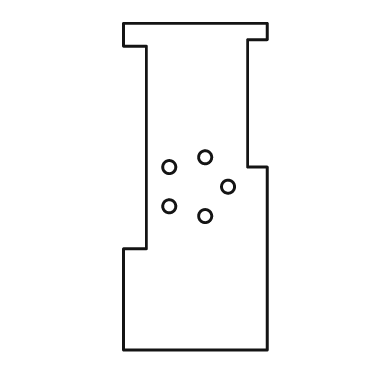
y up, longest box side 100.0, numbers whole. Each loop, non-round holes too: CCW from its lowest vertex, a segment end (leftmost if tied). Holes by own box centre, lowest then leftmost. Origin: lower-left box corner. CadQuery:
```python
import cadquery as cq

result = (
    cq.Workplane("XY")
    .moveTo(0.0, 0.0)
    .lineTo(44.0, 0.0)
    .lineTo(44.0, 56.0)
    .lineTo(38.0, 56.0)
    .lineTo(38.0, 95.0)
    .lineTo(44.0, 95.0)
    .lineTo(44.0, 100.0)
    .lineTo(0.0, 100.0)
    .lineTo(0.0, 93.0)
    .lineTo(7.0, 93.0)
    .lineTo(7.0, 31.0)
    .lineTo(0.0, 31.0)
    .close()
    .moveTo(25.0, 41.0)
    .circle(2.0)
    .moveTo(14.0, 44.0)
    .circle(2.0)
    .moveTo(32.0, 50.0)
    .circle(2.0)
    .moveTo(14.0, 56.0)
    .circle(2.0)
    .moveTo(25.0, 59.0)
    .circle(2.0)
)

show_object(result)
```